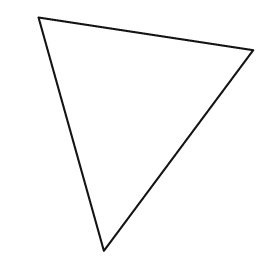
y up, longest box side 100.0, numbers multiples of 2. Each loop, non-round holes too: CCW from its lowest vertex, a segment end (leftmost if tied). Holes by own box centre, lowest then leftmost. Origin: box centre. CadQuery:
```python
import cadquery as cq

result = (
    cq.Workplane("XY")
    .moveTo(-18.0, -50.0)
    .lineTo(46.0, 36.0)
    .lineTo(-46.0, 50.0)
    .close()
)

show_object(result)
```